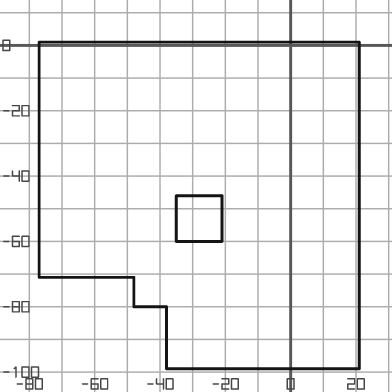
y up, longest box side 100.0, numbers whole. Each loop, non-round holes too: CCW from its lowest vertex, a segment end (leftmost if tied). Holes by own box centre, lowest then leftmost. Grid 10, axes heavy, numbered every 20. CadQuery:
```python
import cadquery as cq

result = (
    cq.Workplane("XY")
    .moveTo(-38.0, -99.0)
    .lineTo(21.0, -99.0)
    .lineTo(21.0, 1.0)
    .lineTo(-77.0, 1.0)
    .lineTo(-77.0, -71.0)
    .lineTo(-48.0, -71.0)
    .lineTo(-48.0, -80.0)
    .lineTo(-38.0, -80.0)
    .close()
    .moveTo(-35.0, -60.0)
    .lineTo(-21.0, -60.0)
    .lineTo(-21.0, -46.0)
    .lineTo(-35.0, -46.0)
    .close()
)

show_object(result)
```